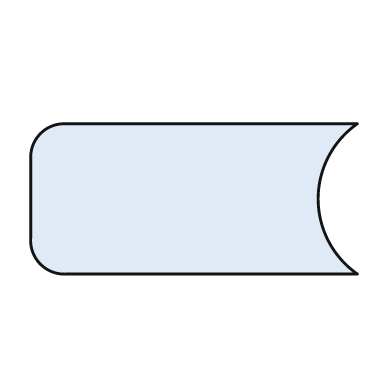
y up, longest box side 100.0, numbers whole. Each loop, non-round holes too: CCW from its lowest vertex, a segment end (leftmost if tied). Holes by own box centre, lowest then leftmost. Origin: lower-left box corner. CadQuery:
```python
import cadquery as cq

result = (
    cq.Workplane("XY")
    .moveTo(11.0, 0.0)
    .lineTo(100.0, 0.0)
    .threePointArc((88.0, 23.0), (100.0, 46.0))
    .lineTo(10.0, 46.0)
    .threePointArc((3.0, 43.0), (0.0, 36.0))
    .lineTo(0.0, 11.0)
    .threePointArc((3.0, 3.0), (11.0, 0.0))
    .close()
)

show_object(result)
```